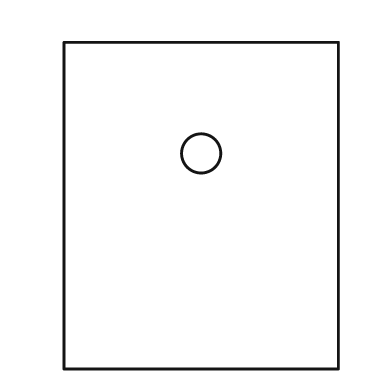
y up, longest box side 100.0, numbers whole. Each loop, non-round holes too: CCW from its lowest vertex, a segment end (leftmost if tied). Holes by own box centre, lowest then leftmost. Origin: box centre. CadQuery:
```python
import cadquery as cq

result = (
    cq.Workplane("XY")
    .moveTo(-42.0, -50.0)
    .lineTo(42.0, -50.0)
    .lineTo(42.0, 50.0)
    .lineTo(-42.0, 50.0)
    .close()
    .moveTo(0.0, 16.0)
    .circle(6.0)
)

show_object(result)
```